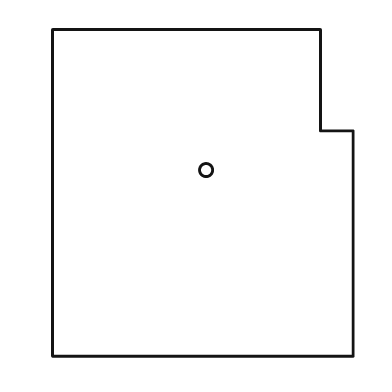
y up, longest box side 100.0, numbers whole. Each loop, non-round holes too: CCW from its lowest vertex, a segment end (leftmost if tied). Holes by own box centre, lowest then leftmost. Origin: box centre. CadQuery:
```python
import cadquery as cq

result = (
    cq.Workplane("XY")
    .moveTo(-46.0, -50.0)
    .lineTo(46.0, -50.0)
    .lineTo(46.0, 19.0)
    .lineTo(36.0, 19.0)
    .lineTo(36.0, 50.0)
    .lineTo(-46.0, 50.0)
    .close()
    .moveTo(1.0, 7.0)
    .circle(2.0)
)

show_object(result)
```